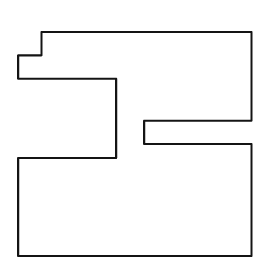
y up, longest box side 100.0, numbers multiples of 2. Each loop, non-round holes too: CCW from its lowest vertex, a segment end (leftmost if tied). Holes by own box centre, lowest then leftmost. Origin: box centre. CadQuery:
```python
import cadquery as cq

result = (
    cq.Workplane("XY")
    .moveTo(-50.0, -48.0)
    .lineTo(50.0, -48.0)
    .lineTo(50.0, 0.0)
    .lineTo(4.0, 0.0)
    .lineTo(4.0, 10.0)
    .lineTo(50.0, 10.0)
    .lineTo(50.0, 48.0)
    .lineTo(-40.0, 48.0)
    .lineTo(-40.0, 38.0)
    .lineTo(-50.0, 38.0)
    .lineTo(-50.0, 28.0)
    .lineTo(-8.0, 28.0)
    .lineTo(-8.0, -6.0)
    .lineTo(-50.0, -6.0)
    .close()
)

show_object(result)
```